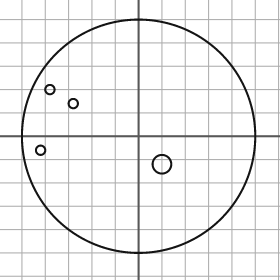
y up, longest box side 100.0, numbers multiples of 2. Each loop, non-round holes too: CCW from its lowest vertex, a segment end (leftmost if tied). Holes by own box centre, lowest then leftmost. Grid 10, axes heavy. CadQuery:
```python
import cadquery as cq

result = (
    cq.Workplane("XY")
    .moveTo(0.0, 0.0)
    .circle(50.0)
    .moveTo(10.0, -12.0)
    .circle(4.0)
    .moveTo(-42.0, -6.0)
    .circle(2.0)
    .moveTo(-28.0, 14.0)
    .circle(2.0)
    .moveTo(-38.0, 20.0)
    .circle(2.0)
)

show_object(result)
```